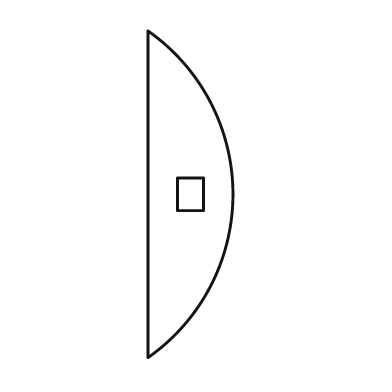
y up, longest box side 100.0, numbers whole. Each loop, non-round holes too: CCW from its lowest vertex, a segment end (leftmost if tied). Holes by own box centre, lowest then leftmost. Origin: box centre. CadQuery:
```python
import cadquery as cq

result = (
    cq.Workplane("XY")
    .moveTo(-13.0, -50.0)
    .threePointArc((13.0, 0.0), (-13.0, 50.0))
    .close()
    .moveTo(-4.0, -5.0)
    .lineTo(4.0, -5.0)
    .lineTo(4.0, 5.0)
    .lineTo(-4.0, 5.0)
    .close()
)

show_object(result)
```